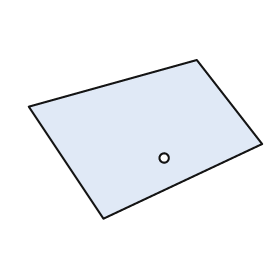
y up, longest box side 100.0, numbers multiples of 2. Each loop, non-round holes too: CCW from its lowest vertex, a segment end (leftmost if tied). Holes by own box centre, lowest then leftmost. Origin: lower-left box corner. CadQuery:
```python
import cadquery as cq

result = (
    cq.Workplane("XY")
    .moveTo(32.0, 0.0)
    .lineTo(100.0, 32.0)
    .lineTo(72.0, 68.0)
    .lineTo(0.0, 48.0)
    .close()
    .moveTo(58.0, 26.0)
    .circle(2.0)
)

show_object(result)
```